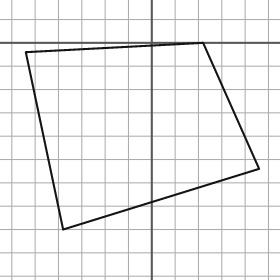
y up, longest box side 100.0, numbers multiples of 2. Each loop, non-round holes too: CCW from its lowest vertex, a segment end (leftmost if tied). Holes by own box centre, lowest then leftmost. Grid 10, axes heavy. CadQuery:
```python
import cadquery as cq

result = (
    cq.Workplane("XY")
    .moveTo(-38.0, -80.0)
    .lineTo(46.0, -54.0)
    .lineTo(22.0, 0.0)
    .lineTo(-54.0, -4.0)
    .close()
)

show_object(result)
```